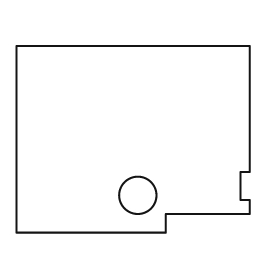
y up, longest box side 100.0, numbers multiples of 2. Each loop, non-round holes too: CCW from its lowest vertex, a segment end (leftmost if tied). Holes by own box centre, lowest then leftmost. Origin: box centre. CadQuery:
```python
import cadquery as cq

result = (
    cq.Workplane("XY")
    .moveTo(-50.0, -40.0)
    .lineTo(14.0, -40.0)
    .lineTo(14.0, -32.0)
    .lineTo(50.0, -32.0)
    .lineTo(50.0, -26.0)
    .lineTo(46.0, -26.0)
    .lineTo(46.0, -14.0)
    .lineTo(50.0, -14.0)
    .lineTo(50.0, 40.0)
    .lineTo(-50.0, 40.0)
    .close()
    .moveTo(2.0, -24.0)
    .circle(8.0)
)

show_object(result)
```